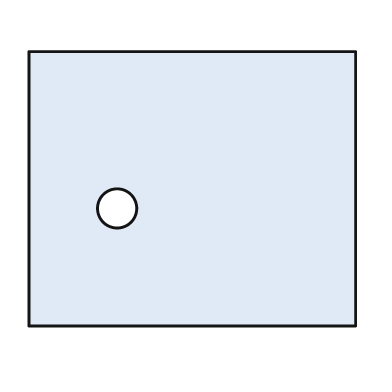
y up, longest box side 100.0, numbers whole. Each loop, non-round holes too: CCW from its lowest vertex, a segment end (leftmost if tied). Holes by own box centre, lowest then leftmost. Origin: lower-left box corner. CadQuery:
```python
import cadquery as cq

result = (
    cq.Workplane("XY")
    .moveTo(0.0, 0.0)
    .lineTo(100.0, 0.0)
    .lineTo(100.0, 84.0)
    .lineTo(0.0, 84.0)
    .close()
    .moveTo(27.0, 36.0)
    .circle(6.0)
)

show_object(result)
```